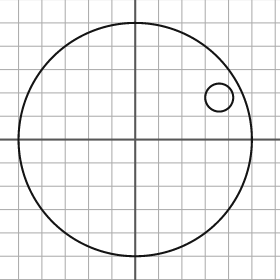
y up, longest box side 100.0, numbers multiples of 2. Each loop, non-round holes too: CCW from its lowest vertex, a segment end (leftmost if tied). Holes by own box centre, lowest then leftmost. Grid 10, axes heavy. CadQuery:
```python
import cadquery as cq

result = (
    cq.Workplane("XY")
    .moveTo(0.0, 0.0)
    .circle(50.0)
    .moveTo(36.0, 18.0)
    .circle(6.0)
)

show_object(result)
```